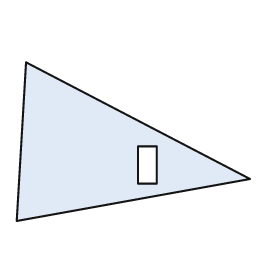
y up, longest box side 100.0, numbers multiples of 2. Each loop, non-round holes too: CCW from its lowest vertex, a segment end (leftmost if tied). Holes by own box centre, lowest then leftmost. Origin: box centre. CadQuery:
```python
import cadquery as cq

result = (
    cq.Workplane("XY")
    .moveTo(-50.0, -34.0)
    .lineTo(50.0, -16.0)
    .lineTo(-46.0, 34.0)
    .close()
    .moveTo(2.0, -18.0)
    .lineTo(10.0, -18.0)
    .lineTo(10.0, -2.0)
    .lineTo(2.0, -2.0)
    .close()
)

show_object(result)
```